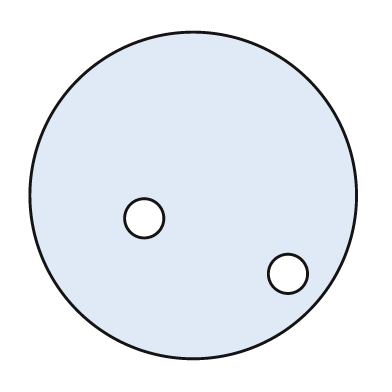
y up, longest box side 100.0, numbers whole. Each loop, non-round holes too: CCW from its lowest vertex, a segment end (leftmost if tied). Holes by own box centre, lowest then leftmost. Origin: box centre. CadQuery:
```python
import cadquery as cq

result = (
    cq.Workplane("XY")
    .moveTo(0.0, 0.0)
    .circle(50.0)
    .moveTo(29.0, -24.0)
    .circle(6.0)
    .moveTo(-15.0, -7.0)
    .circle(6.0)
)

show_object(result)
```